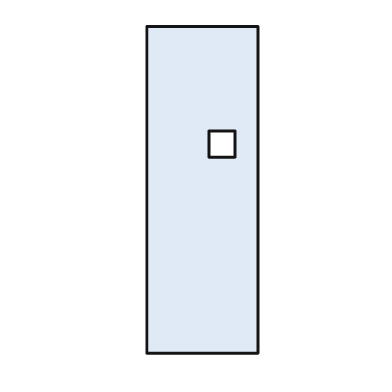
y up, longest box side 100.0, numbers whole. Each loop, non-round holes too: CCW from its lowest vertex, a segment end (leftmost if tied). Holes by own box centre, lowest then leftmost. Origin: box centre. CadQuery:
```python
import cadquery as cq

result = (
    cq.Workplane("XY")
    .moveTo(-17.0, -50.0)
    .lineTo(17.0, -50.0)
    .lineTo(17.0, 50.0)
    .lineTo(-17.0, 50.0)
    .close()
    .moveTo(2.0, 10.0)
    .lineTo(10.0, 10.0)
    .lineTo(10.0, 18.0)
    .lineTo(2.0, 18.0)
    .close()
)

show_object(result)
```